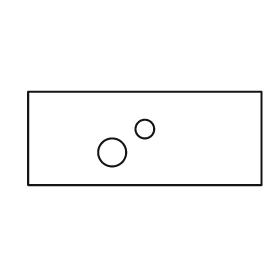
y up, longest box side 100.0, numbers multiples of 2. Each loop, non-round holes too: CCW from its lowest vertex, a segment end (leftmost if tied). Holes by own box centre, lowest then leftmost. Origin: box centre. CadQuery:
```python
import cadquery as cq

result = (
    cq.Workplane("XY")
    .moveTo(-50.0, -20.0)
    .lineTo(50.0, -20.0)
    .lineTo(50.0, 20.0)
    .lineTo(-50.0, 20.0)
    .close()
    .moveTo(-14.0, -6.0)
    .circle(6.0)
    .moveTo(0.0, 4.0)
    .circle(4.0)
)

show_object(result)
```